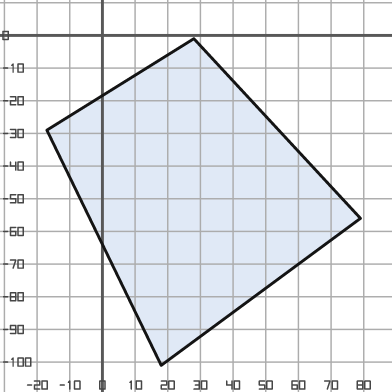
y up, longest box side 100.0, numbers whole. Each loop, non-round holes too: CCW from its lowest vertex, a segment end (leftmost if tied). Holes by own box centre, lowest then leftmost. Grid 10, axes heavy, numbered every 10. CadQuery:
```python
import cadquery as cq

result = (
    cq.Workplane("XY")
    .moveTo(18.0, -101.0)
    .lineTo(79.0, -56.0)
    .lineTo(28.0, -1.0)
    .lineTo(-17.0, -29.0)
    .close()
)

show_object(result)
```